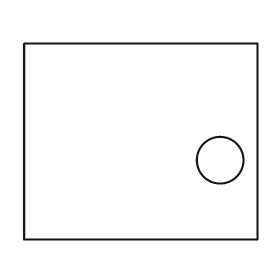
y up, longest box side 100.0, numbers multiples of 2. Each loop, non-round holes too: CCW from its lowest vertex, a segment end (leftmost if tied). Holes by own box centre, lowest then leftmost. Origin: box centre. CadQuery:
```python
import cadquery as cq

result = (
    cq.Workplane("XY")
    .moveTo(-50.0, -42.0)
    .lineTo(50.0, -42.0)
    .lineTo(50.0, 42.0)
    .lineTo(-50.0, 42.0)
    .close()
    .moveTo(34.0, -8.0)
    .circle(10.0)
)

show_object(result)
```